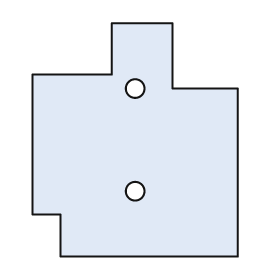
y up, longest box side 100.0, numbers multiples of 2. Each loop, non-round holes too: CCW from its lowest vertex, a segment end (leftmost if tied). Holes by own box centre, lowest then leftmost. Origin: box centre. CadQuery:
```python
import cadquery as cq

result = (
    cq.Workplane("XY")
    .moveTo(-32.0, -50.0)
    .lineTo(44.0, -50.0)
    .lineTo(44.0, 22.0)
    .lineTo(16.0, 22.0)
    .lineTo(16.0, 50.0)
    .lineTo(-10.0, 50.0)
    .lineTo(-10.0, 28.0)
    .lineTo(-44.0, 28.0)
    .lineTo(-44.0, -32.0)
    .lineTo(-32.0, -32.0)
    .close()
    .moveTo(0.0, -22.0)
    .circle(4.0)
    .moveTo(0.0, 22.0)
    .circle(4.0)
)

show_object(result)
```